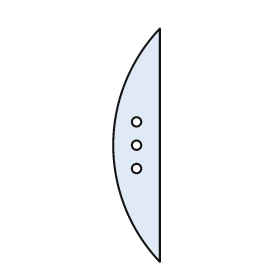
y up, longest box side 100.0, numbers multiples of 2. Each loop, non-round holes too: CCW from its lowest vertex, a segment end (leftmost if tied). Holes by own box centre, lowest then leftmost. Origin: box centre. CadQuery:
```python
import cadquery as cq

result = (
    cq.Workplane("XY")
    .moveTo(10.0, -50.0)
    .lineTo(10.0, 50.0)
    .threePointArc((-10.0, 0.0), (10.0, -50.0))
    .close()
    .moveTo(0.0, -10.0)
    .circle(2.0)
    .moveTo(0.0, 0.0)
    .circle(2.0)
    .moveTo(0.0, 10.0)
    .circle(2.0)
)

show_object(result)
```